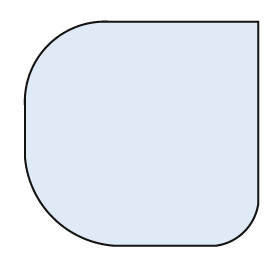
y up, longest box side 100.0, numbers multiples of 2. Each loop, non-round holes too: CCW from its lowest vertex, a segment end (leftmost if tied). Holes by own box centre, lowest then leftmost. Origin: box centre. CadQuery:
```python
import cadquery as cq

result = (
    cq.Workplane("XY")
    .moveTo(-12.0, -48.0)
    .lineTo(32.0, -48.0)
    .threePointArc((44.0, -42.0), (50.0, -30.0))
    .lineTo(50.0, 48.0)
    .lineTo(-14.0, 48.0)
    .threePointArc((-40.0, 38.0), (-50.0, 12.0))
    .lineTo(-50.0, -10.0)
    .threePointArc((-38.0, -36.0), (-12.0, -48.0))
    .close()
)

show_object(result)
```